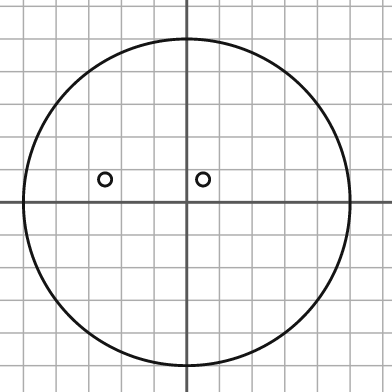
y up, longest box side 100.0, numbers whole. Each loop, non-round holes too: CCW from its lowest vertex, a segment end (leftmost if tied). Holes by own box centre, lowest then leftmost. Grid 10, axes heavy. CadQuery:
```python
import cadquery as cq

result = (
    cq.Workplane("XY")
    .moveTo(0.0, 0.0)
    .circle(50.0)
    .moveTo(-25.0, 7.0)
    .circle(2.0)
    .moveTo(5.0, 7.0)
    .circle(2.0)
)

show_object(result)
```